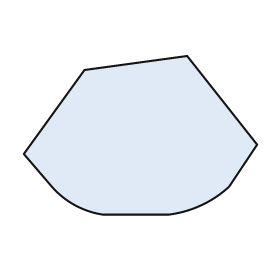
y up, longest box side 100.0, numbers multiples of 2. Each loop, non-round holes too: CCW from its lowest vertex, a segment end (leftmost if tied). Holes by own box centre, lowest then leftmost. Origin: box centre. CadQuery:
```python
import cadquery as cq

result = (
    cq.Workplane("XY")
    .moveTo(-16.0, -34.0)
    .lineTo(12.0, -34.0)
    .threePointArc((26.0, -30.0), (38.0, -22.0))
    .lineTo(50.0, -4.0)
    .lineTo(20.0, 34.0)
    .lineTo(-24.0, 28.0)
    .lineTo(-50.0, -8.0)
    .lineTo(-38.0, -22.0)
    .threePointArc((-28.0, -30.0), (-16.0, -34.0))
    .close()
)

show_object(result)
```